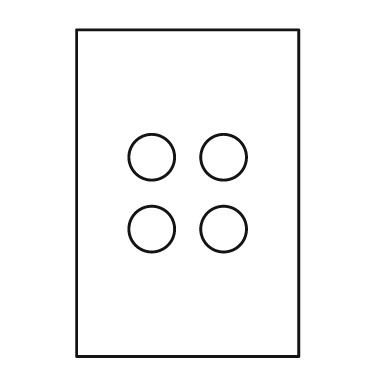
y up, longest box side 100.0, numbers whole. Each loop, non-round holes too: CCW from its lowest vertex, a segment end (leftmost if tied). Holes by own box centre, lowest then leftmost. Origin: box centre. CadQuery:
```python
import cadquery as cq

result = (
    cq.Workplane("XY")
    .moveTo(-34.0, -50.0)
    .lineTo(34.0, -50.0)
    .lineTo(34.0, 50.0)
    .lineTo(-34.0, 50.0)
    .close()
    .moveTo(-11.0, -11.0)
    .circle(7.0)
    .moveTo(11.0, -11.0)
    .circle(7.0)
    .moveTo(-11.0, 11.0)
    .circle(7.0)
    .moveTo(11.0, 11.0)
    .circle(7.0)
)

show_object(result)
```